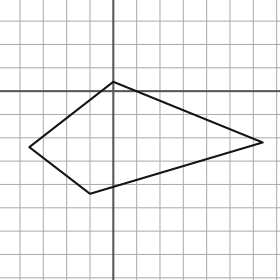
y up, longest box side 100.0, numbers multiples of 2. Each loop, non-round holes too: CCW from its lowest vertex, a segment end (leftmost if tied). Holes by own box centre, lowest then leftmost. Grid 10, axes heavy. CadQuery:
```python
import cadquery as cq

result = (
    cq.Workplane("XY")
    .moveTo(-10.0, -44.0)
    .lineTo(64.0, -22.0)
    .lineTo(0.0, 4.0)
    .lineTo(-36.0, -24.0)
    .close()
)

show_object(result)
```